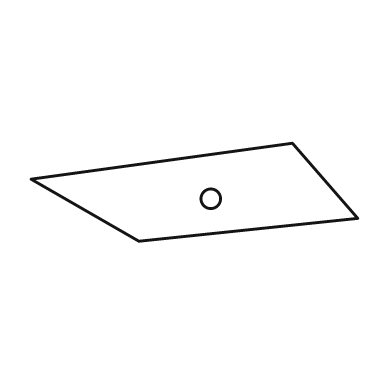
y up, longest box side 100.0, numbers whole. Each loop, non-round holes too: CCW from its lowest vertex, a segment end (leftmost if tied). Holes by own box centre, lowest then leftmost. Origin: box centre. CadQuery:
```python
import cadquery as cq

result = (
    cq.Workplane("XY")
    .moveTo(-17.0, -15.0)
    .lineTo(50.0, -8.0)
    .lineTo(30.0, 15.0)
    .lineTo(-50.0, 4.0)
    .close()
    .moveTo(5.0, -2.0)
    .circle(3.0)
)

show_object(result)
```